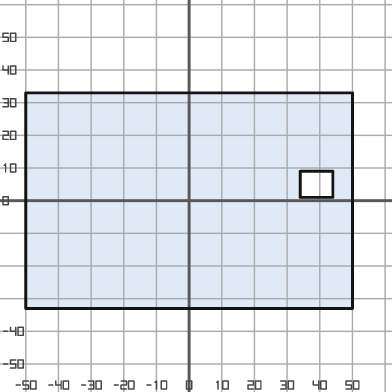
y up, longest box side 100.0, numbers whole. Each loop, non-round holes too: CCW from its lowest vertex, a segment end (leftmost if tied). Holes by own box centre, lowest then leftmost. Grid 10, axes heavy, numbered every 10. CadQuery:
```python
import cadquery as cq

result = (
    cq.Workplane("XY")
    .moveTo(-50.0, -33.0)
    .lineTo(50.0, -33.0)
    .lineTo(50.0, 33.0)
    .lineTo(-50.0, 33.0)
    .close()
    .moveTo(34.0, 1.0)
    .lineTo(44.0, 1.0)
    .lineTo(44.0, 9.0)
    .lineTo(34.0, 9.0)
    .close()
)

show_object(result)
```